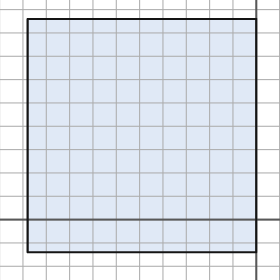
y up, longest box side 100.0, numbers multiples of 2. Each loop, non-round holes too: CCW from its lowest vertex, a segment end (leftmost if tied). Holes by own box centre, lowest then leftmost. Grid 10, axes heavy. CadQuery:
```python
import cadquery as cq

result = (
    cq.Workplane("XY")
    .moveTo(-98.0, -14.0)
    .lineTo(0.0, -14.0)
    .lineTo(0.0, 86.0)
    .lineTo(-98.0, 86.0)
    .close()
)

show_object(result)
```